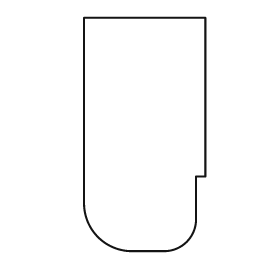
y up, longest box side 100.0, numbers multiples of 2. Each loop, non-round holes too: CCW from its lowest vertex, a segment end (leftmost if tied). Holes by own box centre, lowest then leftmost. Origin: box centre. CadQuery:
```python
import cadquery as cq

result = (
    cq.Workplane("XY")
    .moveTo(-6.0, -50.0)
    .lineTo(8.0, -50.0)
    .threePointArc((18.0, -46.0), (22.0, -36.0))
    .lineTo(22.0, -18.0)
    .lineTo(26.0, -18.0)
    .lineTo(26.0, 50.0)
    .lineTo(-26.0, 50.0)
    .lineTo(-26.0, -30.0)
    .threePointArc((-20.0, -44.0), (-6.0, -50.0))
    .close()
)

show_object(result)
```